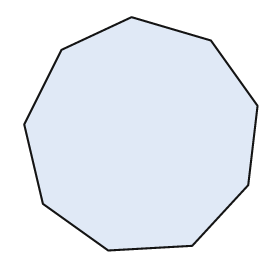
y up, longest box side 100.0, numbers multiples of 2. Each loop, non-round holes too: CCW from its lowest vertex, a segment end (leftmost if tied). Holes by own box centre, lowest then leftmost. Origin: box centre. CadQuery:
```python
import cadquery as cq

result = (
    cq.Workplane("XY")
    .moveTo(-14.0, -50.0)
    .lineTo(22.0, -48.0)
    .lineTo(46.0, -22.0)
    .lineTo(50.0, 12.0)
    .lineTo(30.0, 40.0)
    .lineTo(-4.0, 50.0)
    .lineTo(-34.0, 36.0)
    .lineTo(-50.0, 4.0)
    .lineTo(-42.0, -30.0)
    .close()
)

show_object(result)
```